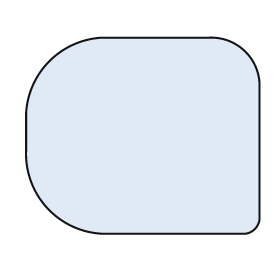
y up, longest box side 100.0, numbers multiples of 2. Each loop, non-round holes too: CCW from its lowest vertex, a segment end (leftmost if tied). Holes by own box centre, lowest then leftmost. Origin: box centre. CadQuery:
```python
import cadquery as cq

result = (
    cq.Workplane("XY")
    .moveTo(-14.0, -42.0)
    .lineTo(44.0, -42.0)
    .threePointArc((48.0, -40.0), (50.0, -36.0))
    .lineTo(50.0, 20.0)
    .threePointArc((44.0, 36.0), (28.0, 42.0))
    .lineTo(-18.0, 42.0)
    .threePointArc((-40.0, 32.0), (-50.0, 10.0))
    .lineTo(-50.0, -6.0)
    .threePointArc((-40.0, -32.0), (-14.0, -42.0))
    .close()
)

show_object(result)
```